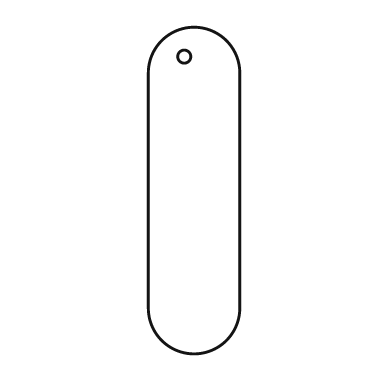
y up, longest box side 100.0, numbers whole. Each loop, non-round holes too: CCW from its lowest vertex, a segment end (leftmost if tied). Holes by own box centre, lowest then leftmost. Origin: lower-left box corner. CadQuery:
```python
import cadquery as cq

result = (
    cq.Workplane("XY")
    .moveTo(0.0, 14.0)
    .threePointArc((14.0, 0.0), (28.0, 14.0))
    .lineTo(28.0, 86.0)
    .threePointArc((14.0, 100.0), (0.0, 86.0))
    .close()
    .moveTo(11.0, 91.0)
    .circle(2.0)
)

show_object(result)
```